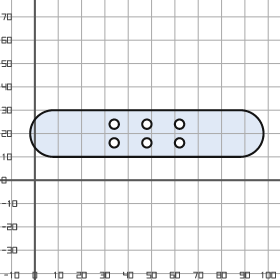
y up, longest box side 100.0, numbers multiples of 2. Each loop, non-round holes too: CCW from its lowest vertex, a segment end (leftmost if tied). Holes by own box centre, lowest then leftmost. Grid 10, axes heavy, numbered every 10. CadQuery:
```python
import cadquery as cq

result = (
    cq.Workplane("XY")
    .moveTo(8.0, 10.0)
    .lineTo(88.0, 10.0)
    .threePointArc((98.0, 20.0), (88.0, 30.0))
    .lineTo(8.0, 30.0)
    .threePointArc((-2.0, 20.0), (8.0, 10.0))
    .close()
    .moveTo(34.0, 16.0)
    .circle(2.0)
    .moveTo(48.0, 16.0)
    .circle(2.0)
    .moveTo(62.0, 16.0)
    .circle(2.0)
    .moveTo(34.0, 24.0)
    .circle(2.0)
    .moveTo(48.0, 24.0)
    .circle(2.0)
    .moveTo(62.0, 24.0)
    .circle(2.0)
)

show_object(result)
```